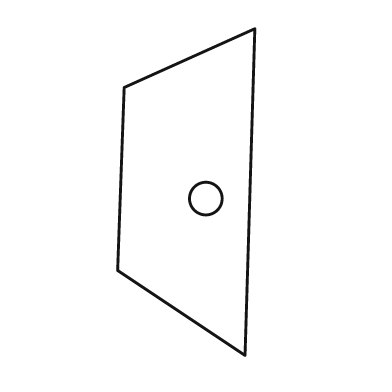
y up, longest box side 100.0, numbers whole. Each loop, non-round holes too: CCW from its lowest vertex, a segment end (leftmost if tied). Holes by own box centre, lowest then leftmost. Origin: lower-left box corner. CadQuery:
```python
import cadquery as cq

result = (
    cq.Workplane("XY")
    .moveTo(39.0, 0.0)
    .lineTo(42.0, 100.0)
    .lineTo(2.0, 82.0)
    .lineTo(0.0, 26.0)
    .close()
    .moveTo(27.0, 48.0)
    .circle(5.0)
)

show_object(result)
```